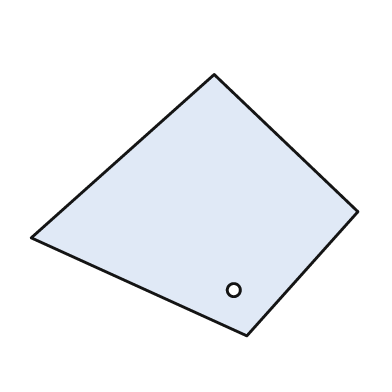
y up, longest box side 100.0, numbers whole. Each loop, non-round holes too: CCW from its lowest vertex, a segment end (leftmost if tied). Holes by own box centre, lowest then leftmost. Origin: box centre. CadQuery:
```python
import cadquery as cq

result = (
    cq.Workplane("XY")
    .moveTo(16.0, -40.0)
    .lineTo(50.0, -2.0)
    .lineTo(6.0, 40.0)
    .lineTo(-50.0, -10.0)
    .close()
    .moveTo(12.0, -26.0)
    .circle(2.0)
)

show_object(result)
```